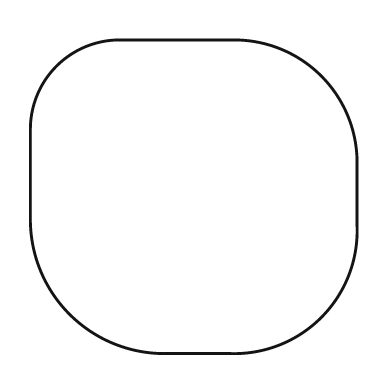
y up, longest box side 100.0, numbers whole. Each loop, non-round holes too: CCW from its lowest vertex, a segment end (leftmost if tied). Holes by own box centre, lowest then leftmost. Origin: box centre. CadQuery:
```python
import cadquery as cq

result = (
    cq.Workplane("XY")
    .moveTo(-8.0, -48.0)
    .lineTo(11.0, -48.0)
    .threePointArc((39.0, -37.0), (50.0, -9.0))
    .lineTo(50.0, 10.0)
    .threePointArc((39.0, 37.0), (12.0, 48.0))
    .lineTo(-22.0, 48.0)
    .threePointArc((-42.0, 40.0), (-50.0, 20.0))
    .lineTo(-50.0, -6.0)
    .threePointArc((-38.0, -36.0), (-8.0, -48.0))
    .close()
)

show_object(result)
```